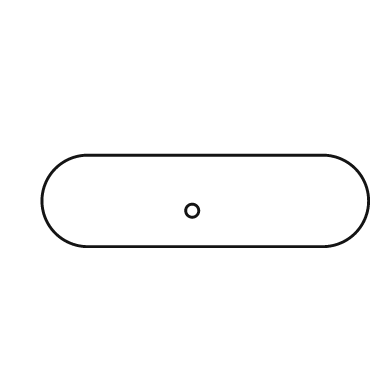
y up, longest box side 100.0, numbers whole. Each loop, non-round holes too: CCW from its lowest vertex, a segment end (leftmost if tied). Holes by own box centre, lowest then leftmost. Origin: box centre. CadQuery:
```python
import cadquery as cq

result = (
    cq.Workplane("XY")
    .moveTo(-36.0, -14.0)
    .lineTo(36.0, -14.0)
    .threePointArc((50.0, 0.0), (36.0, 14.0))
    .lineTo(-36.0, 14.0)
    .threePointArc((-50.0, 0.0), (-36.0, -14.0))
    .close()
    .moveTo(-4.0, -3.0)
    .circle(2.0)
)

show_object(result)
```